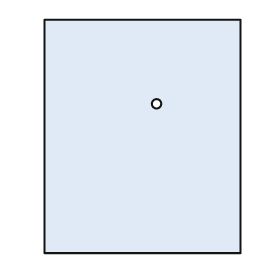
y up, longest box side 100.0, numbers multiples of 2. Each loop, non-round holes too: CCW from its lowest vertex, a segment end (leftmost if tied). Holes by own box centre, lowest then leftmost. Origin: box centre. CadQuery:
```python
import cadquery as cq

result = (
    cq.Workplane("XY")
    .moveTo(-42.0, -50.0)
    .lineTo(42.0, -50.0)
    .lineTo(42.0, 50.0)
    .lineTo(-42.0, 50.0)
    .close()
    .moveTo(6.0, 14.0)
    .circle(2.0)
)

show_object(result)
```